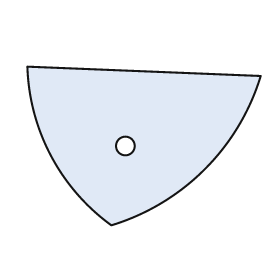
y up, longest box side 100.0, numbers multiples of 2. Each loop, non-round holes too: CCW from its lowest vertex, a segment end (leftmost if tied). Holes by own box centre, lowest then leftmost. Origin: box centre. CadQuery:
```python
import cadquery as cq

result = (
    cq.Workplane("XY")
    .moveTo(-14.0, -34.0)
    .threePointArc((26.0, -10.0), (50.0, 30.0))
    .lineTo(-50.0, 34.0)
    .threePointArc((-40.0, -4.0), (-14.0, -34.0))
    .close()
    .moveTo(-8.0, 0.0)
    .circle(4.0)
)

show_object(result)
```